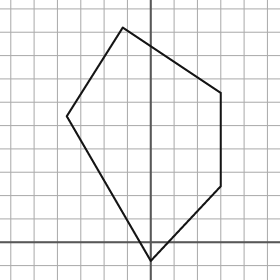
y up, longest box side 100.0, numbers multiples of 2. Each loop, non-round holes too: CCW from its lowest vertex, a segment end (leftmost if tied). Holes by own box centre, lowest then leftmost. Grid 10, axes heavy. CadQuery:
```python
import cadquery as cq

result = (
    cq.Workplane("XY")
    .moveTo(0.0, -8.0)
    .lineTo(30.0, 24.0)
    .lineTo(30.0, 64.0)
    .lineTo(-12.0, 92.0)
    .lineTo(-36.0, 54.0)
    .close()
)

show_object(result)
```